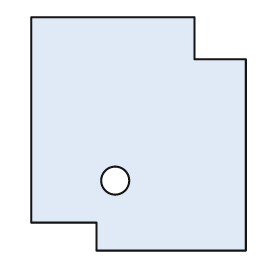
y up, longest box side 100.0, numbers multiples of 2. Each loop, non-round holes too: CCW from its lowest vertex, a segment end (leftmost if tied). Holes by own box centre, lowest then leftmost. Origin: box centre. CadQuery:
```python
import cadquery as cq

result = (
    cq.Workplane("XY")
    .moveTo(-18.0, -50.0)
    .lineTo(46.0, -50.0)
    .lineTo(46.0, 32.0)
    .lineTo(24.0, 32.0)
    .lineTo(24.0, 50.0)
    .lineTo(-46.0, 50.0)
    .lineTo(-46.0, -38.0)
    .lineTo(-18.0, -38.0)
    .close()
    .moveTo(-10.0, -20.0)
    .circle(6.0)
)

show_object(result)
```